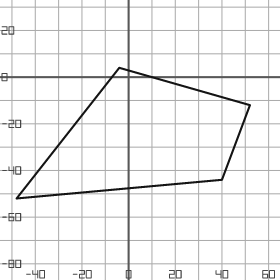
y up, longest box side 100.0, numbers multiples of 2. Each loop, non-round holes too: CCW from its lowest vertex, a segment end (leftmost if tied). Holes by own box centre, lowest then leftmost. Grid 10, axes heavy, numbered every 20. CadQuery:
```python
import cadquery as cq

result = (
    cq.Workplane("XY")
    .moveTo(-48.0, -52.0)
    .lineTo(40.0, -44.0)
    .lineTo(52.0, -12.0)
    .lineTo(-4.0, 4.0)
    .close()
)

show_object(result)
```